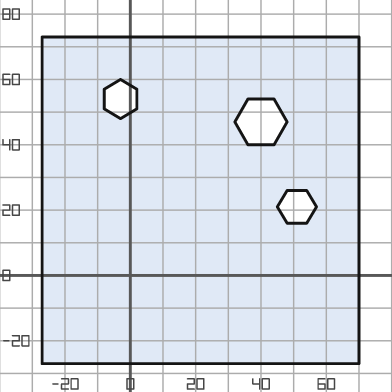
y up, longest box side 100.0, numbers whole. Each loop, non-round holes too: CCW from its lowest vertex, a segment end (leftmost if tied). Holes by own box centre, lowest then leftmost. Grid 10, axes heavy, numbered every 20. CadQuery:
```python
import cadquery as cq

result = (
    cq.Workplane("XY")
    .moveTo(-27.0, -27.0)
    .lineTo(70.0, -27.0)
    .lineTo(70.0, 73.0)
    .lineTo(-27.0, 73.0)
    .close()
    .moveTo(48.0, 16.0)
    .lineTo(54.0, 16.0)
    .lineTo(57.0, 21.0)
    .lineTo(54.0, 26.0)
    .lineTo(48.0, 26.0)
    .lineTo(45.0, 21.0)
    .close()
    .moveTo(36.0, 40.0)
    .lineTo(44.0, 40.0)
    .lineTo(48.0, 47.0)
    .lineTo(44.0, 54.0)
    .lineTo(36.0, 54.0)
    .lineTo(32.0, 47.0)
    .close()
    .moveTo(-3.0, 48.0)
    .lineTo(2.0, 51.0)
    .lineTo(2.0, 57.0)
    .lineTo(-3.0, 60.0)
    .lineTo(-8.0, 57.0)
    .lineTo(-8.0, 51.0)
    .close()
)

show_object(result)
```